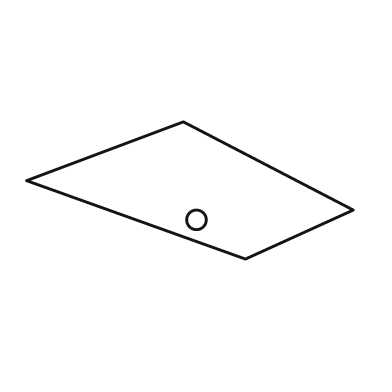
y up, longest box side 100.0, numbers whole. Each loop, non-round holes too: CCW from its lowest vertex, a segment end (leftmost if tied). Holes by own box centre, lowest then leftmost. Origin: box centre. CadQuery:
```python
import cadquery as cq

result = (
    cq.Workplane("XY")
    .moveTo(17.0, -21.0)
    .lineTo(50.0, -6.0)
    .lineTo(-2.0, 21.0)
    .lineTo(-50.0, 3.0)
    .close()
    .moveTo(2.0, -9.0)
    .circle(3.0)
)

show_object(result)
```